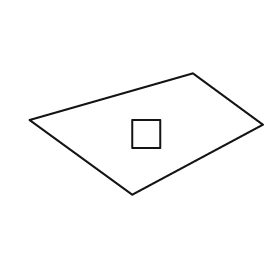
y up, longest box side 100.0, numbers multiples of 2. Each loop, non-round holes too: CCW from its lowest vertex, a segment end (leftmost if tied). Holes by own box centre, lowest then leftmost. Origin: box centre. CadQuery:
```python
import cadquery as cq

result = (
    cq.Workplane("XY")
    .moveTo(-6.0, -26.0)
    .lineTo(50.0, 4.0)
    .lineTo(20.0, 26.0)
    .lineTo(-50.0, 6.0)
    .close()
    .moveTo(-6.0, -6.0)
    .lineTo(6.0, -6.0)
    .lineTo(6.0, 6.0)
    .lineTo(-6.0, 6.0)
    .close()
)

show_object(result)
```